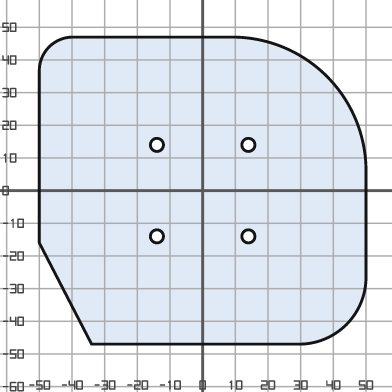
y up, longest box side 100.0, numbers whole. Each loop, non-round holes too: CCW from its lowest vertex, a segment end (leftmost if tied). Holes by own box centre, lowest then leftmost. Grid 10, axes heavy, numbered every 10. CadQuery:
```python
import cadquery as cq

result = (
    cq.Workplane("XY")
    .moveTo(-34.0, -47.0)
    .lineTo(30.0, -47.0)
    .threePointArc((44.0, -41.0), (50.0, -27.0))
    .lineTo(50.0, 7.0)
    .threePointArc((38.0, 35.0), (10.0, 47.0))
    .lineTo(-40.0, 47.0)
    .threePointArc((-47.0, 44.0), (-50.0, 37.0))
    .lineTo(-50.0, -16.0)
    .close()
    .moveTo(-14.0, -14.0)
    .circle(2.0)
    .moveTo(14.0, -14.0)
    .circle(2.0)
    .moveTo(-14.0, 14.0)
    .circle(2.0)
    .moveTo(14.0, 14.0)
    .circle(2.0)
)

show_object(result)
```